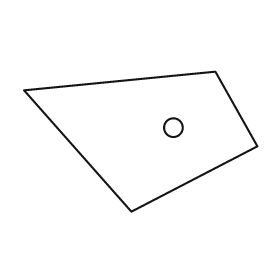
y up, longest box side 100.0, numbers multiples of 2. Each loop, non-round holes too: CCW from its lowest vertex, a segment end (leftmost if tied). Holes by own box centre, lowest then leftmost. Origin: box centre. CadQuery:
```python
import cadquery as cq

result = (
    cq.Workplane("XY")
    .moveTo(-4.0, -30.0)
    .lineTo(50.0, -2.0)
    .lineTo(32.0, 30.0)
    .lineTo(-50.0, 22.0)
    .close()
    .moveTo(14.0, 6.0)
    .circle(4.0)
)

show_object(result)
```